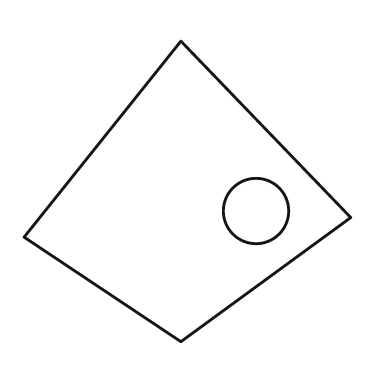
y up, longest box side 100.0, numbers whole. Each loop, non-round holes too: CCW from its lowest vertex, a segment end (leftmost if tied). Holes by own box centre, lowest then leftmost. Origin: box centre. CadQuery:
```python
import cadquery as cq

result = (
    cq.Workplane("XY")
    .moveTo(-2.0, -46.0)
    .lineTo(50.0, -8.0)
    .lineTo(-2.0, 46.0)
    .lineTo(-50.0, -14.0)
    .close()
    .moveTo(21.0, -6.0)
    .circle(10.0)
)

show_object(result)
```